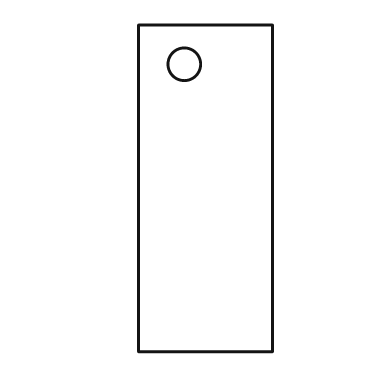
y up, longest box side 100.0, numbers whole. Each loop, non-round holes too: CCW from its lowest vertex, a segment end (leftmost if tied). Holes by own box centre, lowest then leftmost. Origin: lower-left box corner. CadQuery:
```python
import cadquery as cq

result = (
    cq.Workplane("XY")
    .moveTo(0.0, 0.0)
    .lineTo(41.0, 0.0)
    .lineTo(41.0, 100.0)
    .lineTo(0.0, 100.0)
    .close()
    .moveTo(14.0, 88.0)
    .circle(5.0)
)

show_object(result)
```